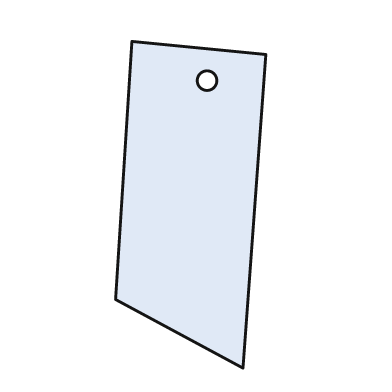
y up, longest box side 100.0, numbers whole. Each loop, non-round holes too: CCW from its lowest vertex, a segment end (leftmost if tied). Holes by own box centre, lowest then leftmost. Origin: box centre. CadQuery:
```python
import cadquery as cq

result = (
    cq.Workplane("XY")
    .moveTo(16.0, -50.0)
    .lineTo(23.0, 46.0)
    .lineTo(-18.0, 50.0)
    .lineTo(-23.0, -29.0)
    .close()
    .moveTo(5.0, 38.0)
    .circle(3.0)
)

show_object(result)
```